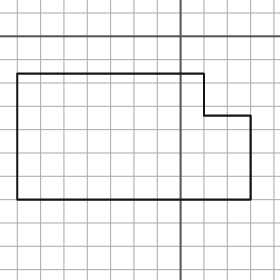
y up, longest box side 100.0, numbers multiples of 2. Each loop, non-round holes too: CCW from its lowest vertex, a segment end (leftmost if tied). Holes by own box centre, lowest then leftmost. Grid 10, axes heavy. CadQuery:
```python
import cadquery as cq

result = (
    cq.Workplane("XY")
    .moveTo(-70.0, -70.0)
    .lineTo(30.0, -70.0)
    .lineTo(30.0, -34.0)
    .lineTo(10.0, -34.0)
    .lineTo(10.0, -16.0)
    .lineTo(-70.0, -16.0)
    .close()
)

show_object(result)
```